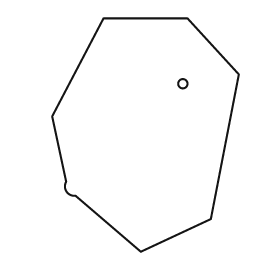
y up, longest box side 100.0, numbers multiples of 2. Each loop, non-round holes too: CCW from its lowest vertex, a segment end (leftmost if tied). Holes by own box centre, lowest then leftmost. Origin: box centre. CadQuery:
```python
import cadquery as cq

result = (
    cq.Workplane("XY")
    .moveTo(-2.0, -50.0)
    .lineTo(28.0, -36.0)
    .lineTo(40.0, 26.0)
    .lineTo(18.0, 50.0)
    .lineTo(-18.0, 50.0)
    .lineTo(-40.0, 8.0)
    .lineTo(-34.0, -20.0)
    .threePointArc((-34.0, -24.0), (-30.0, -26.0))
    .close()
    .moveTo(16.0, 22.0)
    .circle(2.0)
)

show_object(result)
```